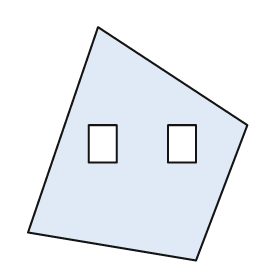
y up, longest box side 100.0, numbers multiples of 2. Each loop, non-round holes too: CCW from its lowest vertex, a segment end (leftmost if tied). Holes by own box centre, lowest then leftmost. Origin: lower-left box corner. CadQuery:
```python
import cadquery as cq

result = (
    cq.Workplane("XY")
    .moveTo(72.0, 0.0)
    .lineTo(94.0, 58.0)
    .lineTo(30.0, 100.0)
    .lineTo(0.0, 12.0)
    .close()
    .moveTo(26.0, 42.0)
    .lineTo(38.0, 42.0)
    .lineTo(38.0, 58.0)
    .lineTo(26.0, 58.0)
    .close()
    .moveTo(60.0, 42.0)
    .lineTo(72.0, 42.0)
    .lineTo(72.0, 58.0)
    .lineTo(60.0, 58.0)
    .close()
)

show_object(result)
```